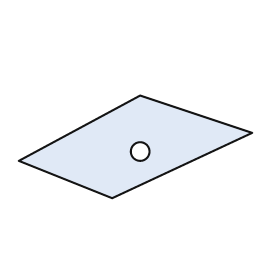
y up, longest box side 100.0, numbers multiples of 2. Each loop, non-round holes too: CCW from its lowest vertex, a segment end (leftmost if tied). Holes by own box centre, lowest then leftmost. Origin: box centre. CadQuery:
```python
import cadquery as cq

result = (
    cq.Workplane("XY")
    .moveTo(-10.0, -22.0)
    .lineTo(50.0, 6.0)
    .lineTo(2.0, 22.0)
    .lineTo(-50.0, -6.0)
    .close()
    .moveTo(2.0, -2.0)
    .circle(4.0)
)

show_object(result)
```